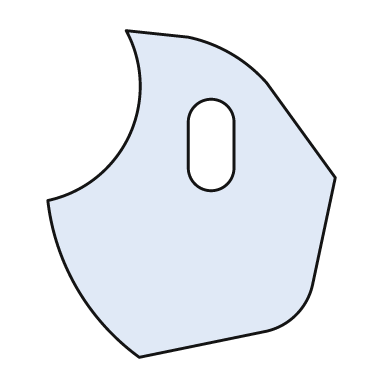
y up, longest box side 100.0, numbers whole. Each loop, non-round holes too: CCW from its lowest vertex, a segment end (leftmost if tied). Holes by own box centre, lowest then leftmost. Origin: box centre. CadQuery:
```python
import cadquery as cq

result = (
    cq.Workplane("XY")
    .moveTo(-16.0, -50.0)
    .lineTo(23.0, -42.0)
    .threePointArc((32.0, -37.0), (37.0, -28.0))
    .lineTo(44.0, 5.0)
    .lineTo(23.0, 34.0)
    .threePointArc((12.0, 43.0), (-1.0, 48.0))
    .lineTo(-20.0, 50.0)
    .threePointArc((-19.0, 18.0), (-44.0, -2.0))
    .threePointArc((-35.0, -29.0), (-16.0, -50.0))
    .close()
    .moveTo(-1.0, 8.0)
    .threePointArc((6.0, 1.0), (13.0, 8.0))
    .lineTo(13.0, 22.0)
    .threePointArc((6.0, 29.0), (-1.0, 22.0))
    .close()
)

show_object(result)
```